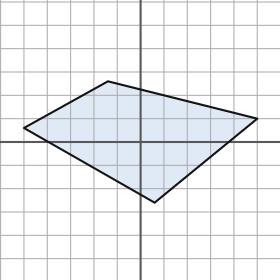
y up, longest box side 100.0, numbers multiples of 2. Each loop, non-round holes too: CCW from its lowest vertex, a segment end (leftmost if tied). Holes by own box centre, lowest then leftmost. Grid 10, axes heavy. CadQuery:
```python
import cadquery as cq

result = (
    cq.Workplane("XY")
    .moveTo(6.0, -26.0)
    .lineTo(50.0, 10.0)
    .lineTo(-14.0, 26.0)
    .lineTo(-50.0, 6.0)
    .close()
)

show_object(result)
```